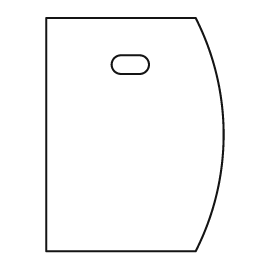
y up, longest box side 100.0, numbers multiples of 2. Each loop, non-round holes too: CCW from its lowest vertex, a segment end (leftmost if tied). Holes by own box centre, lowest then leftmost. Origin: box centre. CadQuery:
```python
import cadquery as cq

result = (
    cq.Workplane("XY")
    .moveTo(-38.0, -50.0)
    .lineTo(26.0, -50.0)
    .threePointArc((38.0, 0.0), (26.0, 50.0))
    .lineTo(-38.0, 50.0)
    .close()
    .moveTo(-6.0, 26.0)
    .lineTo(2.0, 26.0)
    .threePointArc((6.0, 30.0), (2.0, 34.0))
    .lineTo(-6.0, 34.0)
    .threePointArc((-10.0, 30.0), (-6.0, 26.0))
    .close()
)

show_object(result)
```